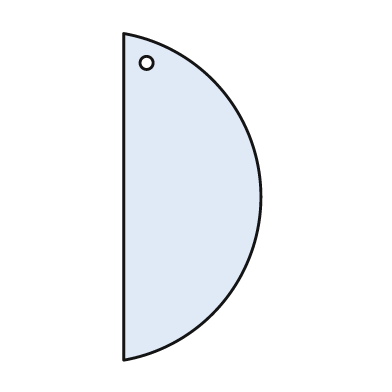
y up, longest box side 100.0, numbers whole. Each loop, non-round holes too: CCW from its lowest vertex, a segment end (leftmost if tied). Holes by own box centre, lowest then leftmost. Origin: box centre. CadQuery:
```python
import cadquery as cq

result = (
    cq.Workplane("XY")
    .moveTo(-21.0, -50.0)
    .threePointArc((21.0, 0.0), (-21.0, 50.0))
    .close()
    .moveTo(-14.0, 41.0)
    .circle(2.0)
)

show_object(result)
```